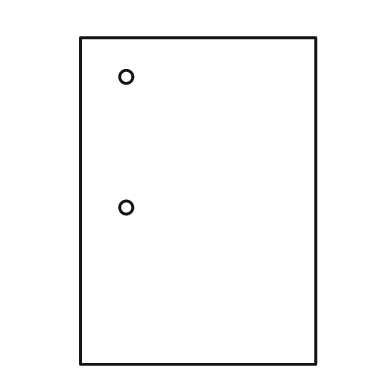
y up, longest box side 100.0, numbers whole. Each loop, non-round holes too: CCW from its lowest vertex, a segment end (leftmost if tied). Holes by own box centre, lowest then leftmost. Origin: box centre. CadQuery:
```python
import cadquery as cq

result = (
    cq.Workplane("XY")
    .moveTo(-36.0, -50.0)
    .lineTo(36.0, -50.0)
    .lineTo(36.0, 50.0)
    .lineTo(-36.0, 50.0)
    .close()
    .moveTo(-22.0, -2.0)
    .circle(2.0)
    .moveTo(-22.0, 38.0)
    .circle(2.0)
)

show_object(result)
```